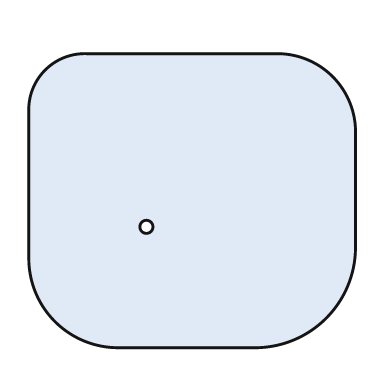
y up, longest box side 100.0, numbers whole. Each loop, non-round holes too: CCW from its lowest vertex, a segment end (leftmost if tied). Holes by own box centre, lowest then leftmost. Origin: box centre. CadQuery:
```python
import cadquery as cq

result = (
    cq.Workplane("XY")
    .moveTo(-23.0, -45.0)
    .lineTo(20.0, -45.0)
    .threePointArc((41.0, -36.0), (50.0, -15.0))
    .lineTo(50.0, 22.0)
    .threePointArc((43.0, 38.0), (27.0, 45.0))
    .lineTo(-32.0, 45.0)
    .threePointArc((-45.0, 40.0), (-50.0, 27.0))
    .lineTo(-50.0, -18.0)
    .threePointArc((-42.0, -37.0), (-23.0, -45.0))
    .close()
    .moveTo(-14.0, -8.0)
    .circle(2.0)
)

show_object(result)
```